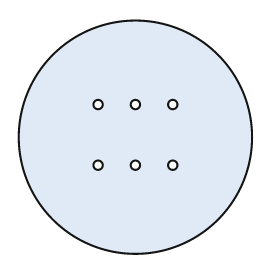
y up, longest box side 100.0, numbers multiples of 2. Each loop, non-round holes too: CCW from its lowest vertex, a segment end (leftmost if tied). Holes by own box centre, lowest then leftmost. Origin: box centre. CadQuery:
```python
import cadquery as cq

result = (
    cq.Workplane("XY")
    .moveTo(0.0, 0.0)
    .circle(50.0)
    .moveTo(-16.0, -12.0)
    .circle(2.0)
    .moveTo(0.0, -12.0)
    .circle(2.0)
    .moveTo(16.0, -12.0)
    .circle(2.0)
    .moveTo(-16.0, 14.0)
    .circle(2.0)
    .moveTo(0.0, 14.0)
    .circle(2.0)
    .moveTo(16.0, 14.0)
    .circle(2.0)
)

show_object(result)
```